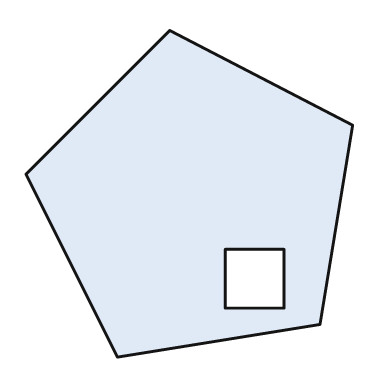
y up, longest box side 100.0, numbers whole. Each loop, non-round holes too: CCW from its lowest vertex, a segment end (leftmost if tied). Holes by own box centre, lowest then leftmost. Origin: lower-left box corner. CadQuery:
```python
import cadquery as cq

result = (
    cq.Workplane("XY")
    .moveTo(28.0, 0.0)
    .lineTo(90.0, 10.0)
    .lineTo(100.0, 71.0)
    .lineTo(44.0, 100.0)
    .lineTo(0.0, 56.0)
    .close()
    .moveTo(61.0, 15.0)
    .lineTo(79.0, 15.0)
    .lineTo(79.0, 33.0)
    .lineTo(61.0, 33.0)
    .close()
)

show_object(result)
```